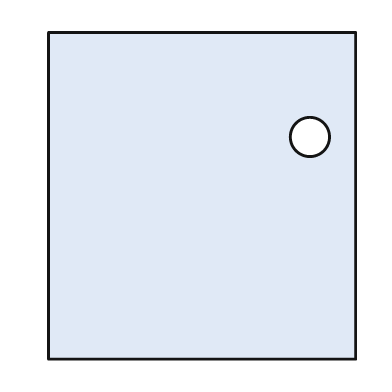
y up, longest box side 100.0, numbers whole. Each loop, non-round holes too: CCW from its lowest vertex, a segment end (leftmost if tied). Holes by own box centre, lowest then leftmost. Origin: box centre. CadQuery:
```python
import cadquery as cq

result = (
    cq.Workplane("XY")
    .moveTo(-47.0, -50.0)
    .lineTo(47.0, -50.0)
    .lineTo(47.0, 50.0)
    .lineTo(-47.0, 50.0)
    .close()
    .moveTo(33.0, 18.0)
    .circle(6.0)
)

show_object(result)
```